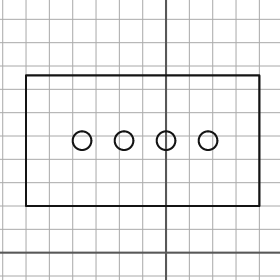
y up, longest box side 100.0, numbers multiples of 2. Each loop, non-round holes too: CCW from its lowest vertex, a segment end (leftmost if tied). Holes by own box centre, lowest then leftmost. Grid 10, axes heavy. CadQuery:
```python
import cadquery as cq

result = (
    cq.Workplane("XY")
    .moveTo(-60.0, 20.0)
    .lineTo(40.0, 20.0)
    .lineTo(40.0, 76.0)
    .lineTo(-60.0, 76.0)
    .close()
    .moveTo(-36.0, 48.0)
    .circle(4.0)
    .moveTo(-18.0, 48.0)
    .circle(4.0)
    .moveTo(0.0, 48.0)
    .circle(4.0)
    .moveTo(18.0, 48.0)
    .circle(4.0)
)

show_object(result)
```